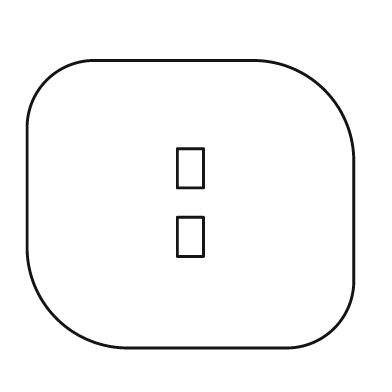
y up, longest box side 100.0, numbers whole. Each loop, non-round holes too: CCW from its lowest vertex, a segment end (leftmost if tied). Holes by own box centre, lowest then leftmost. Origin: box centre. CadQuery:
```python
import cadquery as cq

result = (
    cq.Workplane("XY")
    .moveTo(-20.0, -44.0)
    .lineTo(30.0, -44.0)
    .threePointArc((44.0, -38.0), (50.0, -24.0))
    .lineTo(50.0, 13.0)
    .threePointArc((41.0, 35.0), (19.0, 44.0))
    .lineTo(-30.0, 44.0)
    .threePointArc((-44.0, 38.0), (-50.0, 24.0))
    .lineTo(-50.0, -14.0)
    .threePointArc((-41.0, -35.0), (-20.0, -44.0))
    .close()
    .moveTo(-4.0, -16.0)
    .lineTo(4.0, -16.0)
    .lineTo(4.0, -4.0)
    .lineTo(-4.0, -4.0)
    .close()
    .moveTo(-4.0, 5.0)
    .lineTo(4.0, 5.0)
    .lineTo(4.0, 17.0)
    .lineTo(-4.0, 17.0)
    .close()
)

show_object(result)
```